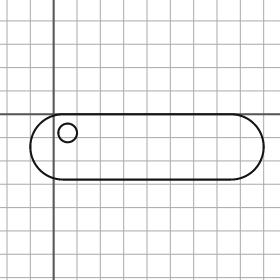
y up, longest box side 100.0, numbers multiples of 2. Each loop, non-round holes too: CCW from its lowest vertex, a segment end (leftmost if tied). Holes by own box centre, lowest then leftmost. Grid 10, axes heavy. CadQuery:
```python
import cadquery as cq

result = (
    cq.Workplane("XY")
    .moveTo(4.0, -28.0)
    .lineTo(76.0, -28.0)
    .threePointArc((90.0, -14.0), (76.0, 0.0))
    .lineTo(4.0, 0.0)
    .threePointArc((-10.0, -14.0), (4.0, -28.0))
    .close()
    .moveTo(6.0, -8.0)
    .circle(4.0)
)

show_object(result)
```